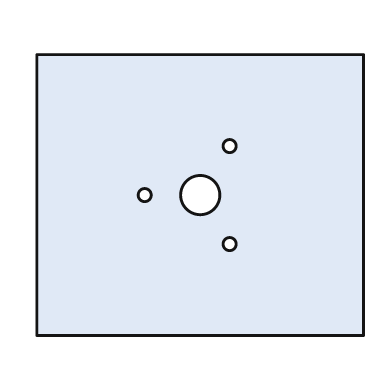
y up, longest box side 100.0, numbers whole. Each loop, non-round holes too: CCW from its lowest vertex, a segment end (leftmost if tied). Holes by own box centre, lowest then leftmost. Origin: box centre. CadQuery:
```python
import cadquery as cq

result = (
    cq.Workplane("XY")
    .moveTo(-50.0, -43.0)
    .lineTo(50.0, -43.0)
    .lineTo(50.0, 43.0)
    .lineTo(-50.0, 43.0)
    .close()
    .moveTo(9.0, -15.0)
    .circle(2.0)
    .moveTo(-17.0, 0.0)
    .circle(2.0)
    .moveTo(0.0, 0.0)
    .circle(6.0)
    .moveTo(9.0, 15.0)
    .circle(2.0)
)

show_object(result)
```